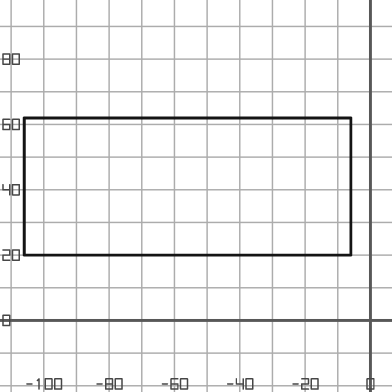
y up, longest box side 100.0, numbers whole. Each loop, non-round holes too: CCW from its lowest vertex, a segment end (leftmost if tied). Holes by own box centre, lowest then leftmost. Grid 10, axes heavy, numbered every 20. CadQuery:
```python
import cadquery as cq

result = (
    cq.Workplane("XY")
    .moveTo(-106.0, 20.0)
    .lineTo(-6.0, 20.0)
    .lineTo(-6.0, 62.0)
    .lineTo(-106.0, 62.0)
    .close()
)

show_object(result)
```